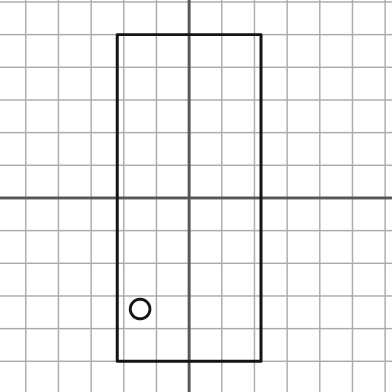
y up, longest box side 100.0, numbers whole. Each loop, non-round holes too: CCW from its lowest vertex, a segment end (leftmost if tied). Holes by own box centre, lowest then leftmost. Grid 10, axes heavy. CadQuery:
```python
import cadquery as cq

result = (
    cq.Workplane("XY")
    .moveTo(-22.0, -50.0)
    .lineTo(22.0, -50.0)
    .lineTo(22.0, 50.0)
    .lineTo(-22.0, 50.0)
    .close()
    .moveTo(-15.0, -34.0)
    .circle(3.0)
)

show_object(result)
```